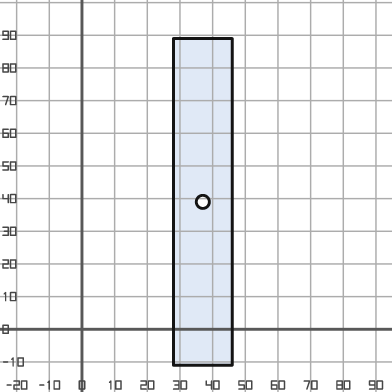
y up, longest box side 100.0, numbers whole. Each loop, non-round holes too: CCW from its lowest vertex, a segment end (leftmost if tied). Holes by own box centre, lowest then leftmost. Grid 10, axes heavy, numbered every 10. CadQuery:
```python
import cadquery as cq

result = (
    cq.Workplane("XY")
    .moveTo(28.0, -11.0)
    .lineTo(46.0, -11.0)
    .lineTo(46.0, 89.0)
    .lineTo(28.0, 89.0)
    .close()
    .moveTo(37.0, 39.0)
    .circle(2.0)
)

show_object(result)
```